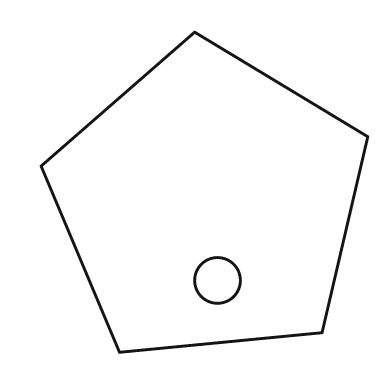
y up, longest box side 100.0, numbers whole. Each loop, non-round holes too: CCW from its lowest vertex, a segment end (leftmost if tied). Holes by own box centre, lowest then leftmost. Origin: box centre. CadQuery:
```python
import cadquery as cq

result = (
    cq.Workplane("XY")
    .moveTo(-26.0, -49.0)
    .lineTo(36.0, -43.0)
    .lineTo(50.0, 17.0)
    .lineTo(-3.0, 49.0)
    .lineTo(-50.0, 8.0)
    .close()
    .moveTo(4.0, -27.0)
    .circle(7.0)
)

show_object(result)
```